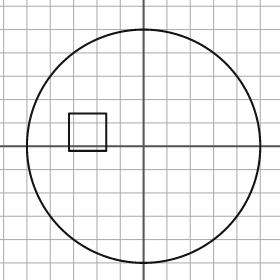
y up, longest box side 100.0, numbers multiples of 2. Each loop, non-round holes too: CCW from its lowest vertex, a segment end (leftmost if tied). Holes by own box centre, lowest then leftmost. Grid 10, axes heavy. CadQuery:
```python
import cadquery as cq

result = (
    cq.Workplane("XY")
    .moveTo(0.0, 0.0)
    .circle(50.0)
    .moveTo(-32.0, -2.0)
    .lineTo(-16.0, -2.0)
    .lineTo(-16.0, 14.0)
    .lineTo(-32.0, 14.0)
    .close()
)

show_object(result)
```